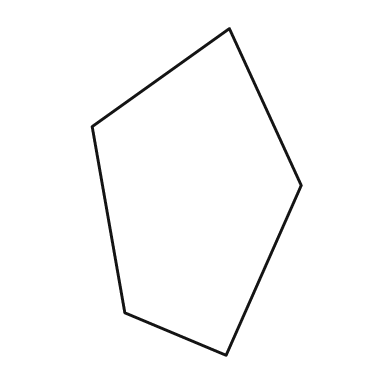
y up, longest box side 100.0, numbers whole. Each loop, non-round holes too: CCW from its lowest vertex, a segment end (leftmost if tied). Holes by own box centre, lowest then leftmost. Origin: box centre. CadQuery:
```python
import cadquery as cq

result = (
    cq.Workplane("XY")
    .moveTo(9.0, -50.0)
    .lineTo(32.0, 2.0)
    .lineTo(10.0, 50.0)
    .lineTo(-32.0, 20.0)
    .lineTo(-22.0, -37.0)
    .close()
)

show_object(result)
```